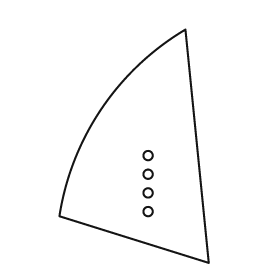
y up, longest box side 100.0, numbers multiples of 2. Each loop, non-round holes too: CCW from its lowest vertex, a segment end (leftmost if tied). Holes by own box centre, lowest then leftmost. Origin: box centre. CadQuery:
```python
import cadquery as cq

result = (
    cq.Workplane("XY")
    .moveTo(32.0, -50.0)
    .lineTo(22.0, 50.0)
    .threePointArc((-14.0, 16.0), (-32.0, -30.0))
    .close()
    .moveTo(6.0, -28.0)
    .circle(2.0)
    .moveTo(6.0, -20.0)
    .circle(2.0)
    .moveTo(6.0, -12.0)
    .circle(2.0)
    .moveTo(6.0, -4.0)
    .circle(2.0)
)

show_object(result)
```